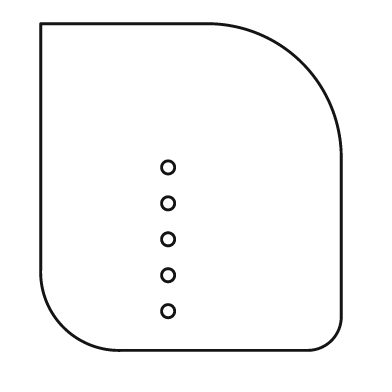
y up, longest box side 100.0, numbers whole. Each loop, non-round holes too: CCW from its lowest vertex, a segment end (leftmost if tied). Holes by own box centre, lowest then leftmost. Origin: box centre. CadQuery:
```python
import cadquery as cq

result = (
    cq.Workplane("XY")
    .moveTo(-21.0, -50.0)
    .lineTo(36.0, -50.0)
    .threePointArc((43.0, -47.0), (46.0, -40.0))
    .lineTo(46.0, 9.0)
    .threePointArc((34.0, 38.0), (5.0, 50.0))
    .lineTo(-46.0, 50.0)
    .lineTo(-46.0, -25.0)
    .threePointArc((-39.0, -43.0), (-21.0, -50.0))
    .close()
    .moveTo(-7.0, -38.0)
    .circle(2.0)
    .moveTo(-7.0, -27.0)
    .circle(2.0)
    .moveTo(-7.0, -16.0)
    .circle(2.0)
    .moveTo(-7.0, -5.0)
    .circle(2.0)
    .moveTo(-7.0, 6.0)
    .circle(2.0)
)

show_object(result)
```